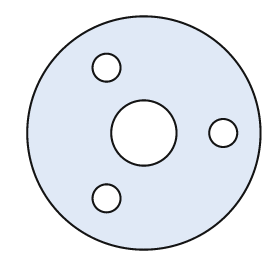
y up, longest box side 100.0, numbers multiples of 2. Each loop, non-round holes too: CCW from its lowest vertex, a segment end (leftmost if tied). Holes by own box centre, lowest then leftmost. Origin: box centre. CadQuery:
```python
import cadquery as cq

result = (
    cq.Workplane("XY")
    .moveTo(0.0, 0.0)
    .circle(50.0)
    .moveTo(-16.0, -28.0)
    .circle(6.0)
    .moveTo(0.0, 0.0)
    .circle(14.0)
    .moveTo(34.0, 0.0)
    .circle(6.0)
    .moveTo(-16.0, 28.0)
    .circle(6.0)
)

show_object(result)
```